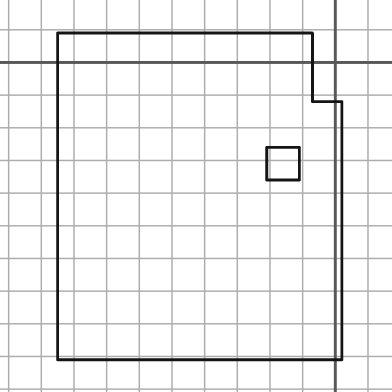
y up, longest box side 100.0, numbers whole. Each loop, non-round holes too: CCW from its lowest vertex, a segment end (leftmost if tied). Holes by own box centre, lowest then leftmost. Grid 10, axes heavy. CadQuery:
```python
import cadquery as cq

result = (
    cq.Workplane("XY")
    .moveTo(-85.0, -91.0)
    .lineTo(2.0, -91.0)
    .lineTo(2.0, -12.0)
    .lineTo(-7.0, -12.0)
    .lineTo(-7.0, 9.0)
    .lineTo(-85.0, 9.0)
    .close()
    .moveTo(-21.0, -36.0)
    .lineTo(-11.0, -36.0)
    .lineTo(-11.0, -26.0)
    .lineTo(-21.0, -26.0)
    .close()
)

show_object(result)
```